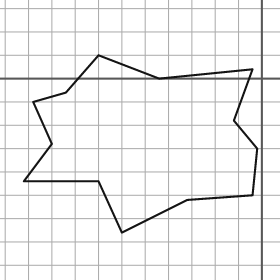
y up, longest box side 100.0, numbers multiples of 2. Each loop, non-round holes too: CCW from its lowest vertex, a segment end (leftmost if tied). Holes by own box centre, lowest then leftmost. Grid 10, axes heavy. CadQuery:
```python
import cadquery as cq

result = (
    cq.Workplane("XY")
    .moveTo(-60.0, -66.0)
    .lineTo(-32.0, -52.0)
    .lineTo(-4.0, -50.0)
    .lineTo(-2.0, -30.0)
    .lineTo(-12.0, -18.0)
    .lineTo(-4.0, 4.0)
    .lineTo(-44.0, 0.0)
    .lineTo(-70.0, 10.0)
    .lineTo(-84.0, -6.0)
    .lineTo(-98.0, -10.0)
    .lineTo(-90.0, -28.0)
    .lineTo(-102.0, -44.0)
    .lineTo(-70.0, -44.0)
    .close()
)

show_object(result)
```